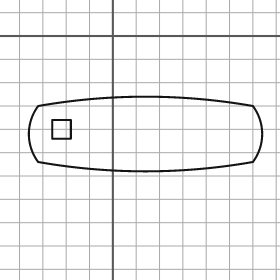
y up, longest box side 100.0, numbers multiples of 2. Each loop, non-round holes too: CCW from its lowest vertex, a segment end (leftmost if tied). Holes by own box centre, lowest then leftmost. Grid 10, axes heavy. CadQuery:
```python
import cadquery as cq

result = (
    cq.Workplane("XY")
    .moveTo(-32.0, -54.0)
    .threePointArc((14.0, -58.0), (60.0, -54.0))
    .threePointArc((64.0, -42.0), (60.0, -30.0))
    .threePointArc((14.0, -26.0), (-32.0, -30.0))
    .threePointArc((-36.0, -42.0), (-32.0, -54.0))
    .close()
    .moveTo(-26.0, -44.0)
    .lineTo(-18.0, -44.0)
    .lineTo(-18.0, -36.0)
    .lineTo(-26.0, -36.0)
    .close()
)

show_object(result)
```